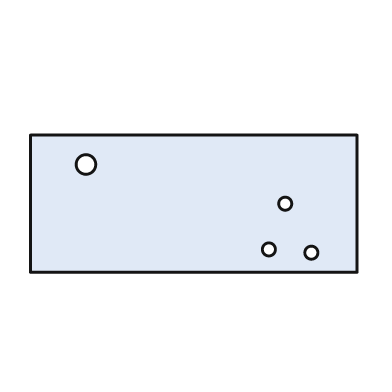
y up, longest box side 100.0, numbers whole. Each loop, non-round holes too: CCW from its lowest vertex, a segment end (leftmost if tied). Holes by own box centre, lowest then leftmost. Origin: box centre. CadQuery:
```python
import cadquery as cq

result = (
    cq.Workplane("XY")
    .moveTo(-50.0, -21.0)
    .lineTo(50.0, -21.0)
    .lineTo(50.0, 21.0)
    .lineTo(-50.0, 21.0)
    .close()
    .moveTo(36.0, -15.0)
    .circle(2.0)
    .moveTo(23.0, -14.0)
    .circle(2.0)
    .moveTo(28.0, 0.0)
    .circle(2.0)
    .moveTo(-33.0, 12.0)
    .circle(3.0)
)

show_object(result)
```